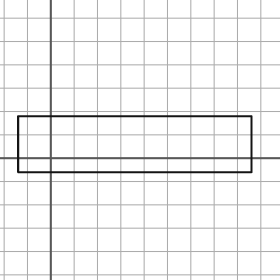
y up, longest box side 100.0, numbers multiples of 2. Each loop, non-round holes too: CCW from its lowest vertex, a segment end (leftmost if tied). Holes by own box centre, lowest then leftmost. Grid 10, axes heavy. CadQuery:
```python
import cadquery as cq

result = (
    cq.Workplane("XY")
    .moveTo(-14.0, -6.0)
    .lineTo(86.0, -6.0)
    .lineTo(86.0, 18.0)
    .lineTo(-14.0, 18.0)
    .close()
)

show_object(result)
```